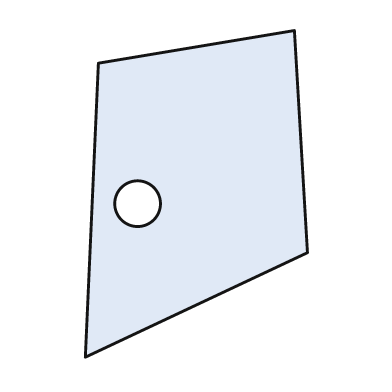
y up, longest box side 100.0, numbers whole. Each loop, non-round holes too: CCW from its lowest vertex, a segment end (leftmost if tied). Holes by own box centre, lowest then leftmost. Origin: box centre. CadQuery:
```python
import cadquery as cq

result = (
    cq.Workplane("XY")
    .moveTo(-34.0, -50.0)
    .lineTo(34.0, -18.0)
    .lineTo(30.0, 50.0)
    .lineTo(-30.0, 40.0)
    .close()
    .moveTo(-18.0, -3.0)
    .circle(7.0)
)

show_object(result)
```